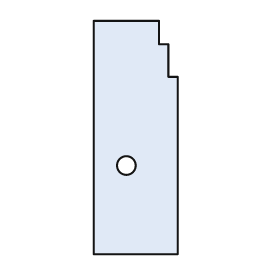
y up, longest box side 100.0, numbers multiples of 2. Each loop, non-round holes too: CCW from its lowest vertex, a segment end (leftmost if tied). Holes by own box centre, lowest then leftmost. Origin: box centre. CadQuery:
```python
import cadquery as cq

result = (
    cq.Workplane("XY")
    .moveTo(-18.0, -50.0)
    .lineTo(18.0, -50.0)
    .lineTo(18.0, 26.0)
    .lineTo(14.0, 26.0)
    .lineTo(14.0, 40.0)
    .lineTo(10.0, 40.0)
    .lineTo(10.0, 50.0)
    .lineTo(-18.0, 50.0)
    .close()
    .moveTo(-4.0, -12.0)
    .circle(4.0)
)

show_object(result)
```